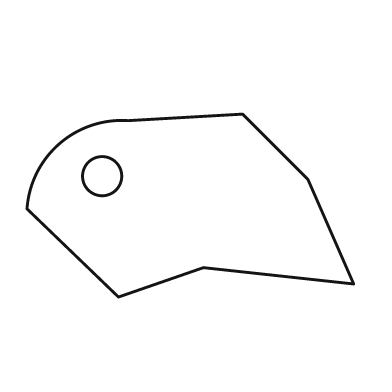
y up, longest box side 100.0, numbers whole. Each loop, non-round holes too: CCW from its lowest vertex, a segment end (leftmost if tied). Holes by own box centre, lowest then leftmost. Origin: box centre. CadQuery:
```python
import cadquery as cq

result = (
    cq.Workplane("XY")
    .moveTo(-22.0, -28.0)
    .lineTo(4.0, -19.0)
    .lineTo(50.0, -24.0)
    .lineTo(36.0, 8.0)
    .lineTo(16.0, 28.0)
    .lineTo(-19.0, 26.0)
    .threePointArc((-40.0, 19.0), (-50.0, -1.0))
    .close()
    .moveTo(-27.0, 9.0)
    .circle(6.0)
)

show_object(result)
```